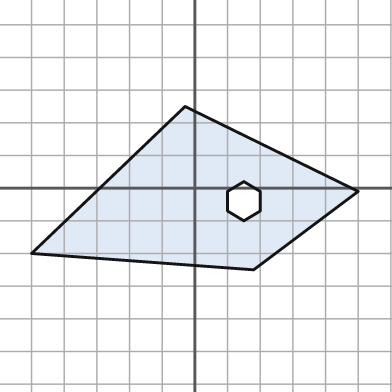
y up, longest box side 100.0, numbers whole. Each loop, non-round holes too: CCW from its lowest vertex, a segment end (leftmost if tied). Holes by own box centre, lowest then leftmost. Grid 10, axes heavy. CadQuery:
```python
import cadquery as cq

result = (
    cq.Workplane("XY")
    .moveTo(18.0, -25.0)
    .lineTo(50.0, -1.0)
    .lineTo(-3.0, 25.0)
    .lineTo(-50.0, -20.0)
    .close()
    .moveTo(15.0, -10.0)
    .lineTo(20.0, -7.0)
    .lineTo(20.0, -1.0)
    .lineTo(15.0, 2.0)
    .lineTo(10.0, -1.0)
    .lineTo(10.0, -7.0)
    .close()
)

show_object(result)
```